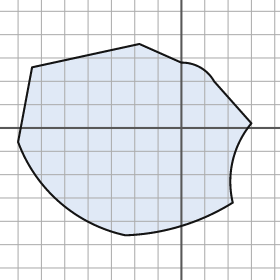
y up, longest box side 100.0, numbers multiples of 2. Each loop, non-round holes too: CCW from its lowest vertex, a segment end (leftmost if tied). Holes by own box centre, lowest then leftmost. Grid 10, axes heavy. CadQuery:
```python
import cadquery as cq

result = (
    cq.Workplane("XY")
    .moveTo(-24.0, -46.0)
    .threePointArc((0.0, -42.0), (22.0, -32.0))
    .threePointArc((22.0, -14.0), (30.0, 2.0))
    .lineTo(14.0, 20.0)
    .threePointArc((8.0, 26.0), (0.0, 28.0))
    .lineTo(-18.0, 36.0)
    .lineTo(-64.0, 26.0)
    .lineTo(-70.0, -6.0)
    .threePointArc((-52.0, -32.0), (-24.0, -46.0))
    .close()
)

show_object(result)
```